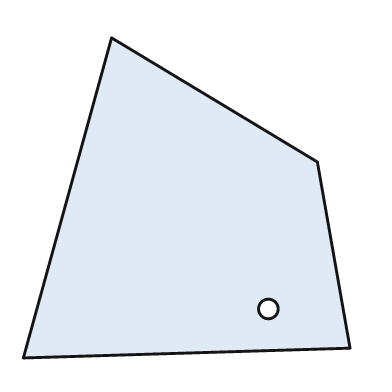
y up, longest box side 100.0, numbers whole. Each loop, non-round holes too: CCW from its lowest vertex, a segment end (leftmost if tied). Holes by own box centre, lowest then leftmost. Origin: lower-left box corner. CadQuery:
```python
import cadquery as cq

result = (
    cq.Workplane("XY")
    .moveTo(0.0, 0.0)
    .lineTo(100.0, 3.0)
    .lineTo(90.0, 60.0)
    .lineTo(27.0, 98.0)
    .close()
    .moveTo(75.0, 15.0)
    .circle(3.0)
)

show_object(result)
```